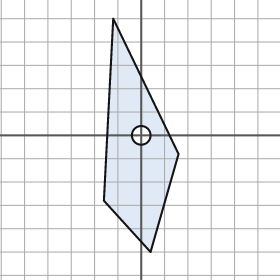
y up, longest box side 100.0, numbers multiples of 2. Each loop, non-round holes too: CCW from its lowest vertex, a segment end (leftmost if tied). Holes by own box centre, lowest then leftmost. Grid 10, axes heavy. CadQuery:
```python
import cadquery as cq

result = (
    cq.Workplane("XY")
    .moveTo(4.0, -50.0)
    .lineTo(16.0, -8.0)
    .lineTo(-12.0, 50.0)
    .lineTo(-16.0, -28.0)
    .close()
    .moveTo(0.0, 0.0)
    .circle(4.0)
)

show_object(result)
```